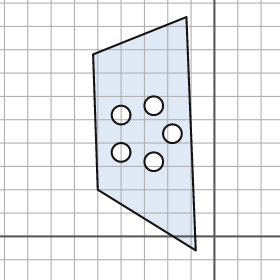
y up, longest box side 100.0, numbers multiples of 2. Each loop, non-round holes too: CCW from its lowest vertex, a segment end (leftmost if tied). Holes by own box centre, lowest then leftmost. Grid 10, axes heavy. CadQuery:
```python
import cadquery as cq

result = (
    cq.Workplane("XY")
    .moveTo(-8.0, -6.0)
    .lineTo(-12.0, 94.0)
    .lineTo(-52.0, 78.0)
    .lineTo(-50.0, 20.0)
    .close()
    .moveTo(-26.0, 32.0)
    .circle(4.0)
    .moveTo(-40.0, 36.0)
    .circle(4.0)
    .moveTo(-18.0, 44.0)
    .circle(4.0)
    .moveTo(-40.0, 52.0)
    .circle(4.0)
    .moveTo(-26.0, 56.0)
    .circle(4.0)
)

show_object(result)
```